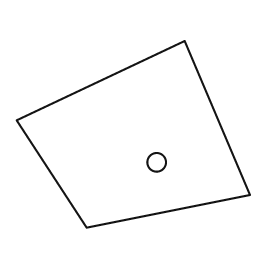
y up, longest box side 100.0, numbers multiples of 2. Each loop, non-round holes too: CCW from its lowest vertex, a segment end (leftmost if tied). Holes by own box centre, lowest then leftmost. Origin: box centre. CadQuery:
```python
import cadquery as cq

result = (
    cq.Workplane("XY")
    .moveTo(-20.0, -40.0)
    .lineTo(50.0, -26.0)
    .lineTo(22.0, 40.0)
    .lineTo(-50.0, 6.0)
    .close()
    .moveTo(10.0, -12.0)
    .circle(4.0)
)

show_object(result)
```